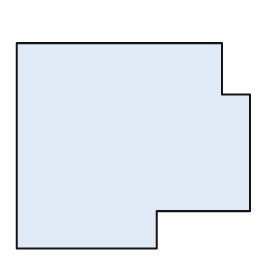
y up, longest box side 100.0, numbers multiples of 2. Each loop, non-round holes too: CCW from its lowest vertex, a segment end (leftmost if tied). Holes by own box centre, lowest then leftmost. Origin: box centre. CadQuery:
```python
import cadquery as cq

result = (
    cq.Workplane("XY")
    .moveTo(-50.0, -44.0)
    .lineTo(10.0, -44.0)
    .lineTo(10.0, -28.0)
    .lineTo(50.0, -28.0)
    .lineTo(50.0, 22.0)
    .lineTo(38.0, 22.0)
    .lineTo(38.0, 44.0)
    .lineTo(-50.0, 44.0)
    .close()
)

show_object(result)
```